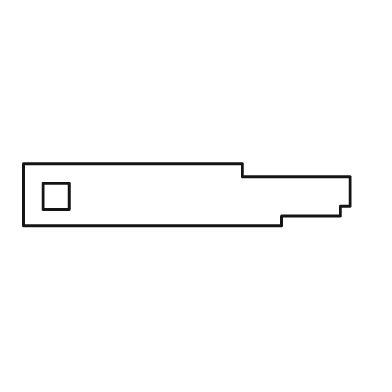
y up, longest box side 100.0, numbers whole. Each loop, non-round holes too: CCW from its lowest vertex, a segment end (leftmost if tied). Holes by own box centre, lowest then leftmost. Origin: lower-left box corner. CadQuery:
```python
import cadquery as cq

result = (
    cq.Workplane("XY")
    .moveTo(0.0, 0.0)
    .lineTo(79.0, 0.0)
    .lineTo(79.0, 3.0)
    .lineTo(97.0, 3.0)
    .lineTo(97.0, 6.0)
    .lineTo(100.0, 6.0)
    .lineTo(100.0, 15.0)
    .lineTo(67.0, 15.0)
    .lineTo(67.0, 19.0)
    .lineTo(0.0, 19.0)
    .close()
    .moveTo(6.0, 5.0)
    .lineTo(14.0, 5.0)
    .lineTo(14.0, 13.0)
    .lineTo(6.0, 13.0)
    .close()
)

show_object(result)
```